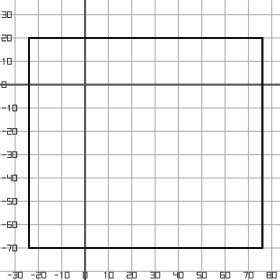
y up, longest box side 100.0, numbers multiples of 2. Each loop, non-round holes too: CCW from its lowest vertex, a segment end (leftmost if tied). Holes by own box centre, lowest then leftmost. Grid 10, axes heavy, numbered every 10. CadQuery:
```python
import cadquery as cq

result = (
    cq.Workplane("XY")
    .moveTo(-24.0, -70.0)
    .lineTo(76.0, -70.0)
    .lineTo(76.0, 20.0)
    .lineTo(-24.0, 20.0)
    .close()
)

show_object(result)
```